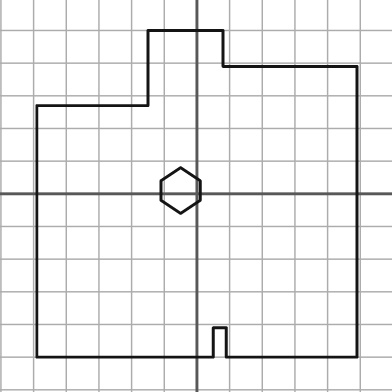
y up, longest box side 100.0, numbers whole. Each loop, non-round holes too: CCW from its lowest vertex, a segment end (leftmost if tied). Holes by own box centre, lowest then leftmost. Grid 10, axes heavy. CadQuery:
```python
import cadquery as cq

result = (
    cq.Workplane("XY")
    .moveTo(-49.0, -50.0)
    .lineTo(5.0, -50.0)
    .lineTo(5.0, -41.0)
    .lineTo(9.0, -41.0)
    .lineTo(9.0, -50.0)
    .lineTo(49.0, -50.0)
    .lineTo(49.0, 39.0)
    .lineTo(8.0, 39.0)
    .lineTo(8.0, 50.0)
    .lineTo(-15.0, 50.0)
    .lineTo(-15.0, 27.0)
    .lineTo(-49.0, 27.0)
    .close()
    .moveTo(-5.0, -6.0)
    .lineTo(1.0, -2.0)
    .lineTo(1.0, 4.0)
    .lineTo(-5.0, 8.0)
    .lineTo(-11.0, 4.0)
    .lineTo(-11.0, -2.0)
    .close()
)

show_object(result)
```